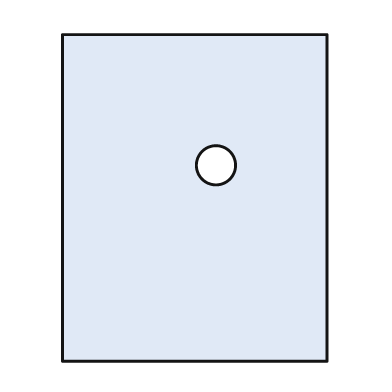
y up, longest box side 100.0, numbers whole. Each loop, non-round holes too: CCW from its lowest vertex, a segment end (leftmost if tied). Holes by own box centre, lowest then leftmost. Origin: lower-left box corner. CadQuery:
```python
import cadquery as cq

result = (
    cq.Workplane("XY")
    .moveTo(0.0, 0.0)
    .lineTo(81.0, 0.0)
    .lineTo(81.0, 100.0)
    .lineTo(0.0, 100.0)
    .close()
    .moveTo(47.0, 60.0)
    .circle(6.0)
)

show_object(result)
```